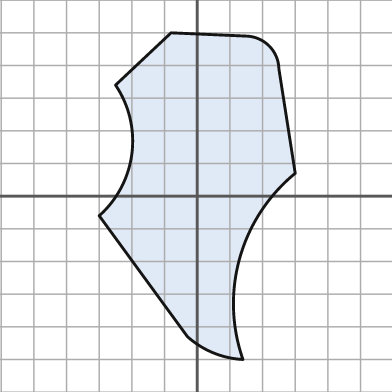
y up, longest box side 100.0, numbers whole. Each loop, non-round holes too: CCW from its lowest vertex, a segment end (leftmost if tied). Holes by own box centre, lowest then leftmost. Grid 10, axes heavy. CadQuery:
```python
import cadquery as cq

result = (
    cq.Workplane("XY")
    .moveTo(14.0, -50.0)
    .threePointArc((13.0, -19.0), (30.0, 7.0))
    .lineTo(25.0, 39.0)
    .threePointArc((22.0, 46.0), (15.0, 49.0))
    .lineTo(-8.0, 50.0)
    .lineTo(-25.0, 34.0)
    .threePointArc((-20.0, 13.0), (-30.0, -6.0))
    .lineTo(-3.0, -43.0)
    .threePointArc((5.0, -48.0), (14.0, -50.0))
    .close()
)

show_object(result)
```